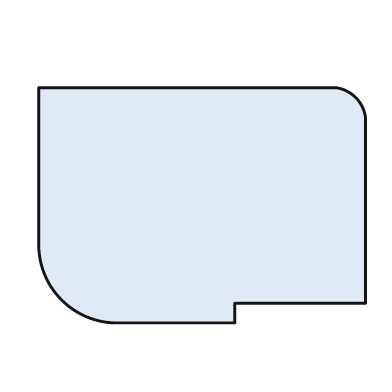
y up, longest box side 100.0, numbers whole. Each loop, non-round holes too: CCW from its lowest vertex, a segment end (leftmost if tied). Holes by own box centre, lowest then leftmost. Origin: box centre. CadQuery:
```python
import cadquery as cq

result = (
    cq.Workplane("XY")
    .moveTo(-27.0, -36.0)
    .lineTo(10.0, -36.0)
    .lineTo(10.0, -30.0)
    .lineTo(50.0, -30.0)
    .lineTo(50.0, 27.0)
    .threePointArc((47.0, 33.0), (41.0, 36.0))
    .lineTo(-50.0, 36.0)
    .lineTo(-50.0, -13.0)
    .threePointArc((-43.0, -29.0), (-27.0, -36.0))
    .close()
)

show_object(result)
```